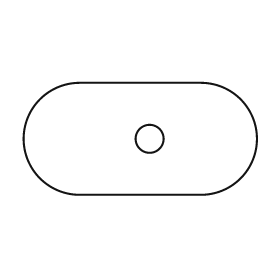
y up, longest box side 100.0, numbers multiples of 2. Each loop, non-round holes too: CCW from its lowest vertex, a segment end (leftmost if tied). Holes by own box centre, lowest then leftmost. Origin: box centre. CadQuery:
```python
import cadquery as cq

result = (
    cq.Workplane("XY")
    .moveTo(-26.0, -24.0)
    .lineTo(26.0, -24.0)
    .threePointArc((50.0, 0.0), (26.0, 24.0))
    .lineTo(-26.0, 24.0)
    .threePointArc((-50.0, 0.0), (-26.0, -24.0))
    .close()
    .moveTo(4.0, 0.0)
    .circle(6.0)
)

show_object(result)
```